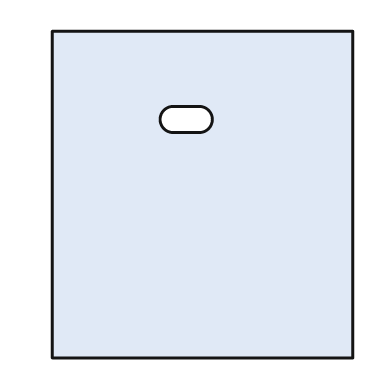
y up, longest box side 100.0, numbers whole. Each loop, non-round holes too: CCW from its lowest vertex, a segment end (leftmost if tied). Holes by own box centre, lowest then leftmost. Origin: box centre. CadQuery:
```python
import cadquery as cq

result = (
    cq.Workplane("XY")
    .moveTo(-46.0, -50.0)
    .lineTo(46.0, -50.0)
    .lineTo(46.0, 50.0)
    .lineTo(-46.0, 50.0)
    .close()
    .moveTo(-9.0, 19.0)
    .lineTo(-1.0, 19.0)
    .threePointArc((3.0, 23.0), (-1.0, 27.0))
    .lineTo(-9.0, 27.0)
    .threePointArc((-13.0, 23.0), (-9.0, 19.0))
    .close()
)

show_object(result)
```